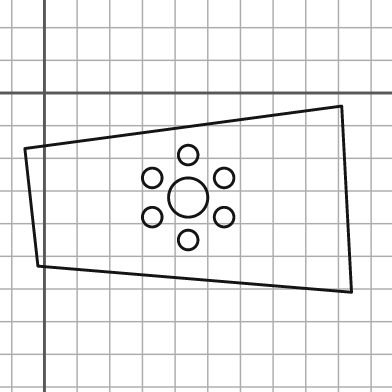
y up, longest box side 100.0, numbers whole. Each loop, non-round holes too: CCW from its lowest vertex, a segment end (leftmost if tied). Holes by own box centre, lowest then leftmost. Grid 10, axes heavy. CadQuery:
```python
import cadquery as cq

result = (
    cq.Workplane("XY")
    .moveTo(94.0, -61.0)
    .lineTo(91.0, -4.0)
    .lineTo(-6.0, -17.0)
    .lineTo(-2.0, -53.0)
    .close()
    .moveTo(44.0, -45.0)
    .circle(3.0)
    .moveTo(33.0, -38.0)
    .circle(3.0)
    .moveTo(55.0, -38.0)
    .circle(3.0)
    .moveTo(44.0, -32.0)
    .circle(6.0)
    .moveTo(33.0, -26.0)
    .circle(3.0)
    .moveTo(55.0, -26.0)
    .circle(3.0)
    .moveTo(44.0, -19.0)
    .circle(3.0)
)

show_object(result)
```